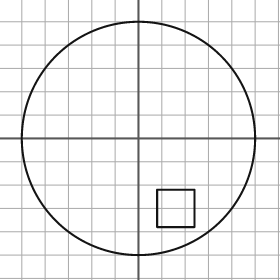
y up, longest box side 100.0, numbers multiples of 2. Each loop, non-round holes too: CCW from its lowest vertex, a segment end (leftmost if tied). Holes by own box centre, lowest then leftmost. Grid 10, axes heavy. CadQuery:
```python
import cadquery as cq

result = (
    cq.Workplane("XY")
    .moveTo(0.0, 0.0)
    .circle(50.0)
    .moveTo(8.0, -38.0)
    .lineTo(24.0, -38.0)
    .lineTo(24.0, -22.0)
    .lineTo(8.0, -22.0)
    .close()
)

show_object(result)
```